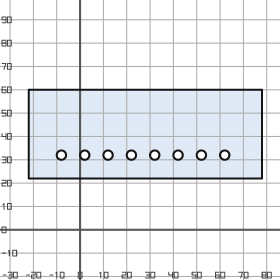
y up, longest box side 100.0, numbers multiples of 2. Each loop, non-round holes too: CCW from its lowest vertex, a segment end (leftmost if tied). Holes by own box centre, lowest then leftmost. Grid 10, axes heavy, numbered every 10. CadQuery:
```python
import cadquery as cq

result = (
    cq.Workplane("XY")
    .moveTo(-22.0, 22.0)
    .lineTo(78.0, 22.0)
    .lineTo(78.0, 60.0)
    .lineTo(-22.0, 60.0)
    .close()
    .moveTo(-8.0, 32.0)
    .circle(2.0)
    .moveTo(2.0, 32.0)
    .circle(2.0)
    .moveTo(12.0, 32.0)
    .circle(2.0)
    .moveTo(22.0, 32.0)
    .circle(2.0)
    .moveTo(32.0, 32.0)
    .circle(2.0)
    .moveTo(42.0, 32.0)
    .circle(2.0)
    .moveTo(52.0, 32.0)
    .circle(2.0)
    .moveTo(62.0, 32.0)
    .circle(2.0)
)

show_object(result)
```